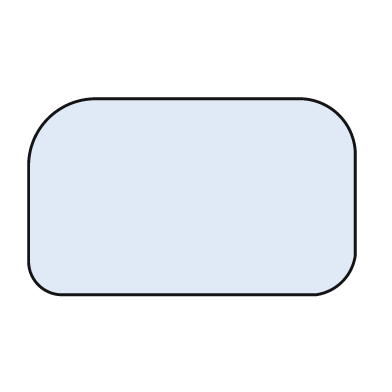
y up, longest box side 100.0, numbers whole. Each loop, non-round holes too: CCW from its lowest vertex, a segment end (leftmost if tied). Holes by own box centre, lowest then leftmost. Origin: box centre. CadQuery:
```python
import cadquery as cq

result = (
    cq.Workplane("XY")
    .moveTo(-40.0, -30.0)
    .lineTo(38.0, -30.0)
    .threePointArc((46.0, -26.0), (50.0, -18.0))
    .lineTo(50.0, 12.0)
    .threePointArc((45.0, 25.0), (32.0, 30.0))
    .lineTo(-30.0, 30.0)
    .threePointArc((-44.0, 24.0), (-50.0, 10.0))
    .lineTo(-50.0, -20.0)
    .threePointArc((-47.0, -27.0), (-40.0, -30.0))
    .close()
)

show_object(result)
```